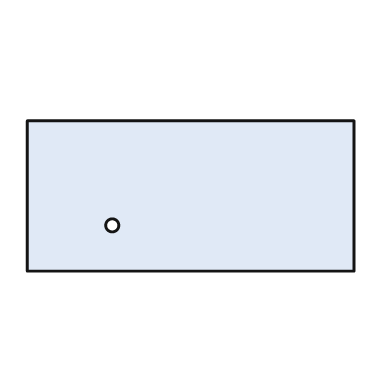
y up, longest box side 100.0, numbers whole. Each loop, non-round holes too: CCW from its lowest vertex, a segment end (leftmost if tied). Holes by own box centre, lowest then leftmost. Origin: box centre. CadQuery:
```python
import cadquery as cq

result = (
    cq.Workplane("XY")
    .moveTo(-50.0, -23.0)
    .lineTo(50.0, -23.0)
    .lineTo(50.0, 23.0)
    .lineTo(-50.0, 23.0)
    .close()
    .moveTo(-24.0, -9.0)
    .circle(2.0)
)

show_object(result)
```